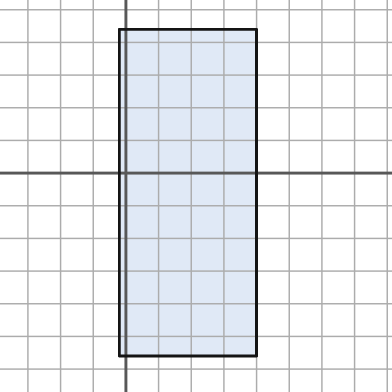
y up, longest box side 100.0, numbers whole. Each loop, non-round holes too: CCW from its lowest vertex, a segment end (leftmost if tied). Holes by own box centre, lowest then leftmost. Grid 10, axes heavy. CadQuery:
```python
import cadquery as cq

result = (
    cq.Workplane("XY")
    .moveTo(-2.0, -56.0)
    .lineTo(40.0, -56.0)
    .lineTo(40.0, 44.0)
    .lineTo(-2.0, 44.0)
    .close()
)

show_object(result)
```